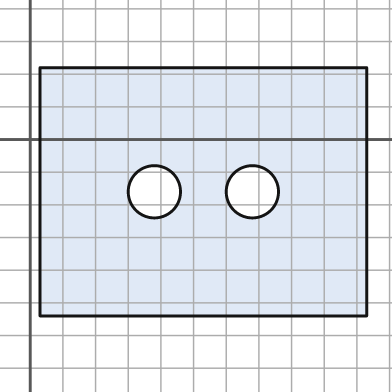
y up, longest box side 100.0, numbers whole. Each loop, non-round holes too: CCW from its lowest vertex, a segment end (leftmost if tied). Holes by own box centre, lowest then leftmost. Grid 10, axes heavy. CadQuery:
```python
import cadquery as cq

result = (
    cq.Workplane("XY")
    .moveTo(3.0, -54.0)
    .lineTo(103.0, -54.0)
    .lineTo(103.0, 22.0)
    .lineTo(3.0, 22.0)
    .close()
    .moveTo(38.0, -16.0)
    .circle(8.0)
    .moveTo(68.0, -16.0)
    .circle(8.0)
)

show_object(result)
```